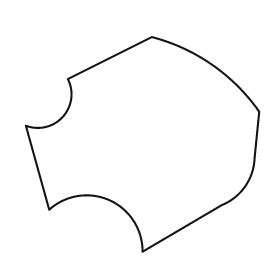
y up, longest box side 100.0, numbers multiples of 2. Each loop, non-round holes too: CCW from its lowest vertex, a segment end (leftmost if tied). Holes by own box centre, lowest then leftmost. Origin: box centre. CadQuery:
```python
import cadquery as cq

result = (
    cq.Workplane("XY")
    .moveTo(0.0, -46.0)
    .lineTo(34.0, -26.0)
    .threePointArc((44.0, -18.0), (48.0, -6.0))
    .lineTo(50.0, 14.0)
    .threePointArc((30.0, 34.0), (4.0, 46.0))
    .lineTo(-32.0, 28.0)
    .threePointArc((-34.0, 12.0), (-50.0, 8.0))
    .lineTo(-40.0, -28.0)
    .threePointArc((-14.0, -24.0), (0.0, -46.0))
    .close()
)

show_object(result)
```